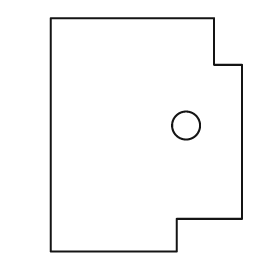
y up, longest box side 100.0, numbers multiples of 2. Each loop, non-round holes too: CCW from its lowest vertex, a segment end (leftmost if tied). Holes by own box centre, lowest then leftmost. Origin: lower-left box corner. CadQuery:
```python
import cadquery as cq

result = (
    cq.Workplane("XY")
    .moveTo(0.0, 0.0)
    .lineTo(54.0, 0.0)
    .lineTo(54.0, 14.0)
    .lineTo(82.0, 14.0)
    .lineTo(82.0, 80.0)
    .lineTo(70.0, 80.0)
    .lineTo(70.0, 100.0)
    .lineTo(0.0, 100.0)
    .close()
    .moveTo(58.0, 54.0)
    .circle(6.0)
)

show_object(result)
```